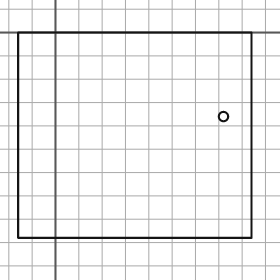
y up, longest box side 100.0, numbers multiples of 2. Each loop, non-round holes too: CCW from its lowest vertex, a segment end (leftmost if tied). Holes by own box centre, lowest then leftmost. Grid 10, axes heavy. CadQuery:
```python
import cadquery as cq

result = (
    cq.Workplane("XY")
    .moveTo(-16.0, -88.0)
    .lineTo(84.0, -88.0)
    .lineTo(84.0, 0.0)
    .lineTo(-16.0, 0.0)
    .close()
    .moveTo(72.0, -36.0)
    .circle(2.0)
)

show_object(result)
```